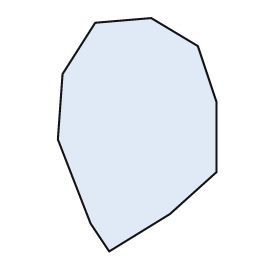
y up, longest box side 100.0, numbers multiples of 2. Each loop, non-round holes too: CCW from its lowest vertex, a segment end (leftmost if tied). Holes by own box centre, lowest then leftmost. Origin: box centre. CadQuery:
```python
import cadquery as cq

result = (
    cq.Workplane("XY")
    .moveTo(-12.0, -50.0)
    .lineTo(14.0, -34.0)
    .lineTo(34.0, -16.0)
    .lineTo(34.0, 14.0)
    .lineTo(26.0, 38.0)
    .lineTo(6.0, 50.0)
    .lineTo(-18.0, 48.0)
    .lineTo(-32.0, 26.0)
    .lineTo(-34.0, -2.0)
    .lineTo(-20.0, -38.0)
    .close()
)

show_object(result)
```